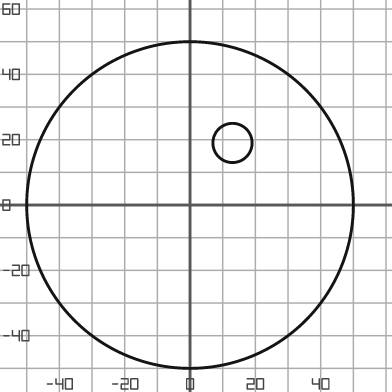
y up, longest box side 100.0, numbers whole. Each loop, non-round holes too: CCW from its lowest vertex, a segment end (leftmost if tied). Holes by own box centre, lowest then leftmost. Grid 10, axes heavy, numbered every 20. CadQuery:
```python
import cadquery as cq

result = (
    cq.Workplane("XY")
    .moveTo(0.0, 0.0)
    .circle(50.0)
    .moveTo(13.0, 19.0)
    .circle(6.0)
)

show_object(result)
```